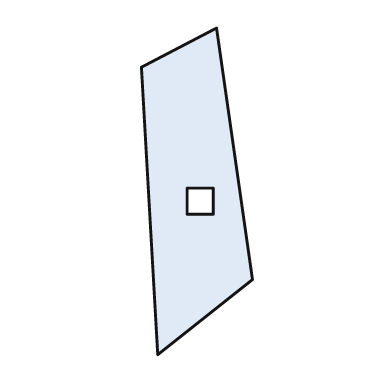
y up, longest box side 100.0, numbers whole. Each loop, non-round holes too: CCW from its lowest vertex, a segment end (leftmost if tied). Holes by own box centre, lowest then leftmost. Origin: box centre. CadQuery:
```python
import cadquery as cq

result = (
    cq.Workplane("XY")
    .moveTo(-12.0, -50.0)
    .lineTo(17.0, -27.0)
    .lineTo(6.0, 50.0)
    .lineTo(-17.0, 38.0)
    .close()
    .moveTo(-3.0, -7.0)
    .lineTo(5.0, -7.0)
    .lineTo(5.0, 1.0)
    .lineTo(-3.0, 1.0)
    .close()
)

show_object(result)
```